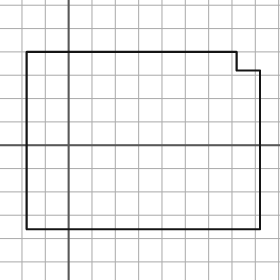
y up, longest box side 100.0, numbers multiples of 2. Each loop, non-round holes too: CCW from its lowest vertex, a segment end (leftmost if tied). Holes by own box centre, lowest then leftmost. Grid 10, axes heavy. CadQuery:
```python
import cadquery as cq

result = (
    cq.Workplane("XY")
    .moveTo(-18.0, -36.0)
    .lineTo(82.0, -36.0)
    .lineTo(82.0, 32.0)
    .lineTo(72.0, 32.0)
    .lineTo(72.0, 40.0)
    .lineTo(-18.0, 40.0)
    .close()
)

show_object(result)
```